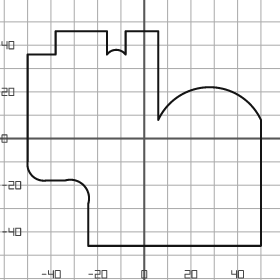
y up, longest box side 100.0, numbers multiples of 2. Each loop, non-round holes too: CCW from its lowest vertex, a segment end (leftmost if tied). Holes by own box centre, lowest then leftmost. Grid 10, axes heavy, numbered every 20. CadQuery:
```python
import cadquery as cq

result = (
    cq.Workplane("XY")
    .moveTo(-24.0, -46.0)
    .lineTo(50.0, -46.0)
    .lineTo(50.0, 8.0)
    .threePointArc((28.0, 22.0), (6.0, 8.0))
    .lineTo(6.0, 46.0)
    .lineTo(-8.0, 46.0)
    .lineTo(-8.0, 36.0)
    .threePointArc((-12.0, 38.0), (-16.0, 36.0))
    .lineTo(-16.0, 46.0)
    .lineTo(-38.0, 46.0)
    .lineTo(-38.0, 36.0)
    .lineTo(-50.0, 36.0)
    .lineTo(-50.0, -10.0)
    .threePointArc((-48.0, -16.0), (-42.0, -18.0))
    .lineTo(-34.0, -18.0)
    .threePointArc((-26.0, -20.0), (-24.0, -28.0))
    .close()
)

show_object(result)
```